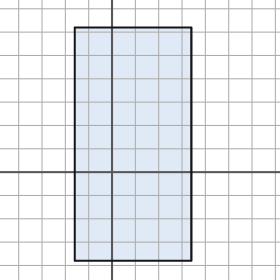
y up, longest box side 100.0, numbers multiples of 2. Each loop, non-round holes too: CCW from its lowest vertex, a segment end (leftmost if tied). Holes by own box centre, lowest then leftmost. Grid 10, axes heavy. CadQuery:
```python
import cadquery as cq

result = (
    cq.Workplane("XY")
    .moveTo(-16.0, -38.0)
    .lineTo(34.0, -38.0)
    .lineTo(34.0, 62.0)
    .lineTo(-16.0, 62.0)
    .close()
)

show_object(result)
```